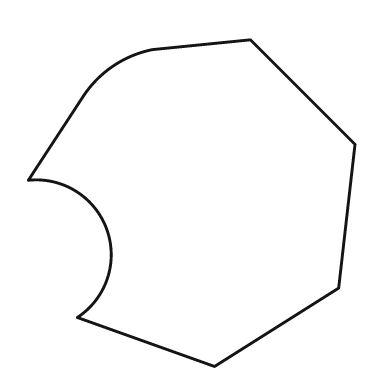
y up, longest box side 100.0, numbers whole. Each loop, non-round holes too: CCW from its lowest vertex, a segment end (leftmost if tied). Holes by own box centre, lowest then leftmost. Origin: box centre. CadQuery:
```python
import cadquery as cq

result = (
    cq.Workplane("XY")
    .moveTo(7.0, -50.0)
    .lineTo(45.0, -26.0)
    .lineTo(50.0, 18.0)
    .lineTo(18.0, 50.0)
    .lineTo(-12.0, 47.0)
    .threePointArc((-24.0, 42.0), (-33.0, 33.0))
    .lineTo(-50.0, 7.0)
    .threePointArc((-26.0, -8.0), (-35.0, -35.0))
    .close()
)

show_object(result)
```